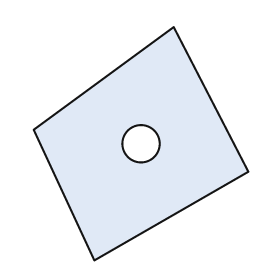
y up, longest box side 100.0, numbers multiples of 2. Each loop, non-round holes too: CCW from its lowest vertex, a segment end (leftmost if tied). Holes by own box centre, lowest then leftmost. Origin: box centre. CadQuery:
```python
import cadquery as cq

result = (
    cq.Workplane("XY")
    .moveTo(-20.0, -50.0)
    .lineTo(46.0, -12.0)
    .lineTo(14.0, 50.0)
    .lineTo(-46.0, 6.0)
    .close()
    .moveTo(0.0, 0.0)
    .circle(8.0)
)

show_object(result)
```